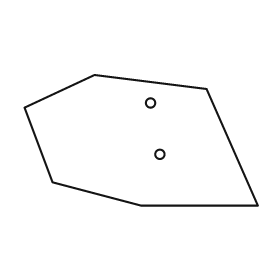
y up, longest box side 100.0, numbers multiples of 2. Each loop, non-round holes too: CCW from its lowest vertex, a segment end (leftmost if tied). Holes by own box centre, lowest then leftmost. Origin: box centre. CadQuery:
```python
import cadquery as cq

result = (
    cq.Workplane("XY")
    .moveTo(0.0, -28.0)
    .lineTo(50.0, -28.0)
    .lineTo(28.0, 22.0)
    .lineTo(-20.0, 28.0)
    .lineTo(-50.0, 14.0)
    .lineTo(-38.0, -18.0)
    .close()
    .moveTo(8.0, -6.0)
    .circle(2.0)
    .moveTo(4.0, 16.0)
    .circle(2.0)
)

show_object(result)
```